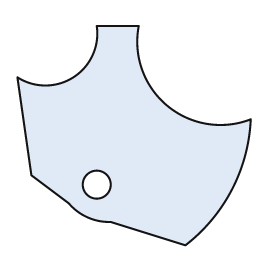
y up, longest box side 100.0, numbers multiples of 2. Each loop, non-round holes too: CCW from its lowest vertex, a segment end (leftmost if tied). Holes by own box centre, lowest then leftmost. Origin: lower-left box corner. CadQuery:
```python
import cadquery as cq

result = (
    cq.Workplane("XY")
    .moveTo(72.0, 0.0)
    .threePointArc((92.0, 24.0), (100.0, 54.0))
    .threePointArc((64.0, 60.0), (52.0, 94.0))
    .lineTo(34.0, 94.0)
    .threePointArc((24.0, 72.0), (0.0, 72.0))
    .lineTo(6.0, 30.0)
    .lineTo(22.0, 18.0)
    .threePointArc((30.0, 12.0), (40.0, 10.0))
    .close()
    .moveTo(34.0, 26.0)
    .circle(6.0)
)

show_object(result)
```